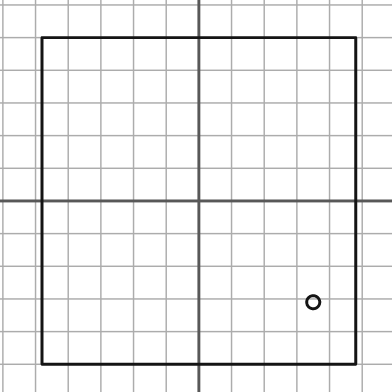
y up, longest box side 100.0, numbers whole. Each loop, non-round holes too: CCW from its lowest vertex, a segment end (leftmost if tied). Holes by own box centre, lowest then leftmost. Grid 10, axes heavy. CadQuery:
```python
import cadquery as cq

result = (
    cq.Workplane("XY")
    .moveTo(-48.0, -50.0)
    .lineTo(48.0, -50.0)
    .lineTo(48.0, 50.0)
    .lineTo(-48.0, 50.0)
    .close()
    .moveTo(35.0, -31.0)
    .circle(2.0)
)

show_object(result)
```